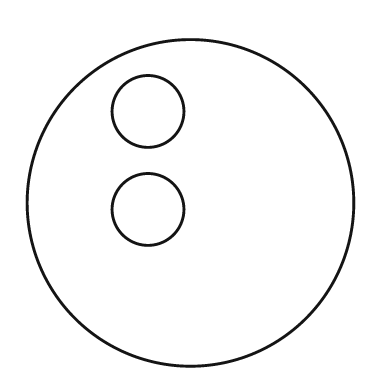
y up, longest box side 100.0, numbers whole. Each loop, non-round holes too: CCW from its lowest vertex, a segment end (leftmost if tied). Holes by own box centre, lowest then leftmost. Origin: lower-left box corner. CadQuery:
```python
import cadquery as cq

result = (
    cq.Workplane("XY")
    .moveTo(50.0, 50.0)
    .circle(50.0)
    .moveTo(37.0, 48.0)
    .circle(11.0)
    .moveTo(37.0, 78.0)
    .circle(11.0)
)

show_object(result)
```